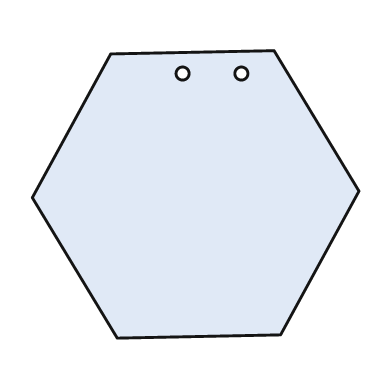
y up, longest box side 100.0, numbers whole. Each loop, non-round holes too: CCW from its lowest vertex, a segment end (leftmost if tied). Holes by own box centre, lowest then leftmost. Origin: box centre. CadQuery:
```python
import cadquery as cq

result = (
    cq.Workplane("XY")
    .moveTo(-24.0, -44.0)
    .lineTo(26.0, -43.0)
    .lineTo(50.0, 1.0)
    .lineTo(24.0, 44.0)
    .lineTo(-26.0, 43.0)
    .lineTo(-50.0, -1.0)
    .close()
    .moveTo(-4.0, 37.0)
    .circle(2.0)
    .moveTo(14.0, 37.0)
    .circle(2.0)
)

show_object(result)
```